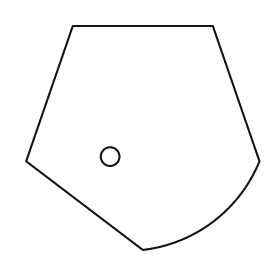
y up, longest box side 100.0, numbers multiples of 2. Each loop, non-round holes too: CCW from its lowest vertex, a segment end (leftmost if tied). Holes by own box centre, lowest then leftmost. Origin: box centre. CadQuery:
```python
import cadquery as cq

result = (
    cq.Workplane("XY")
    .moveTo(0.0, -48.0)
    .threePointArc((30.0, -36.0), (50.0, -10.0))
    .lineTo(30.0, 48.0)
    .lineTo(-30.0, 48.0)
    .lineTo(-50.0, -10.0)
    .close()
    .moveTo(-14.0, -8.0)
    .circle(4.0)
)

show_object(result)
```